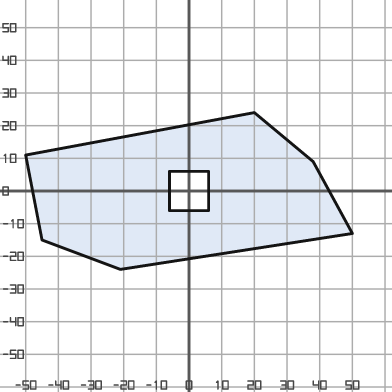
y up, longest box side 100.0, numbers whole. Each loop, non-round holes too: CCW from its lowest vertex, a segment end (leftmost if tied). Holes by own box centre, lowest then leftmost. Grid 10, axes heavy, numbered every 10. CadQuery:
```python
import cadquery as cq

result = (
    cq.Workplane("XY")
    .moveTo(-21.0, -24.0)
    .lineTo(50.0, -13.0)
    .lineTo(38.0, 9.0)
    .lineTo(20.0, 24.0)
    .lineTo(-50.0, 11.0)
    .lineTo(-45.0, -15.0)
    .close()
    .moveTo(-6.0, -6.0)
    .lineTo(6.0, -6.0)
    .lineTo(6.0, 6.0)
    .lineTo(-6.0, 6.0)
    .close()
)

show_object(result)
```